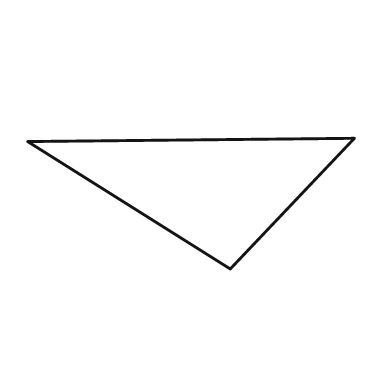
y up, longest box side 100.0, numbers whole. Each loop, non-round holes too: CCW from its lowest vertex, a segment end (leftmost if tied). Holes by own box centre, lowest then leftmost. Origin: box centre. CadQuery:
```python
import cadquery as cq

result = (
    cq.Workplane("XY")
    .moveTo(12.0, -20.0)
    .lineTo(50.0, 20.0)
    .lineTo(-50.0, 19.0)
    .close()
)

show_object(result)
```